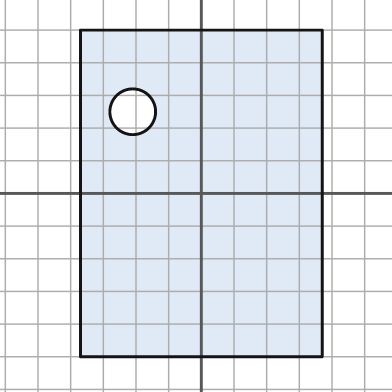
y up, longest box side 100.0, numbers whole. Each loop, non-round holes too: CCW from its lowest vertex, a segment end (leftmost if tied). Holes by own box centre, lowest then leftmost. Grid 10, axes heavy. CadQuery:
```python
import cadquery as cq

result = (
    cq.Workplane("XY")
    .moveTo(-37.0, -50.0)
    .lineTo(37.0, -50.0)
    .lineTo(37.0, 50.0)
    .lineTo(-37.0, 50.0)
    .close()
    .moveTo(-21.0, 25.0)
    .circle(7.0)
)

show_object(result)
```